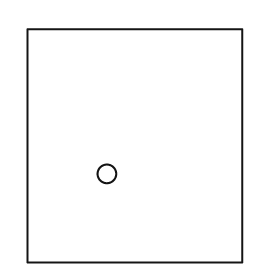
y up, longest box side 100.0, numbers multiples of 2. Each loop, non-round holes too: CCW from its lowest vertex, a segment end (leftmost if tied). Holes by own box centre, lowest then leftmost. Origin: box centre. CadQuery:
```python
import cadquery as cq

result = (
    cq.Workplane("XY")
    .moveTo(-46.0, -50.0)
    .lineTo(46.0, -50.0)
    .lineTo(46.0, 50.0)
    .lineTo(-46.0, 50.0)
    .close()
    .moveTo(-12.0, -12.0)
    .circle(4.0)
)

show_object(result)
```